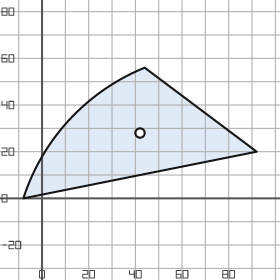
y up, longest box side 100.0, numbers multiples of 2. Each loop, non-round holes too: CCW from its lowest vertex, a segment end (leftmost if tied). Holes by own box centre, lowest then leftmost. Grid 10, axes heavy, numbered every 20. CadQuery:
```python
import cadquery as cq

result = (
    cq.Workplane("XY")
    .moveTo(-8.0, 0.0)
    .lineTo(92.0, 20.0)
    .lineTo(44.0, 56.0)
    .threePointArc((12.0, 34.0), (-8.0, 0.0))
    .close()
    .moveTo(42.0, 28.0)
    .circle(2.0)
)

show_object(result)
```